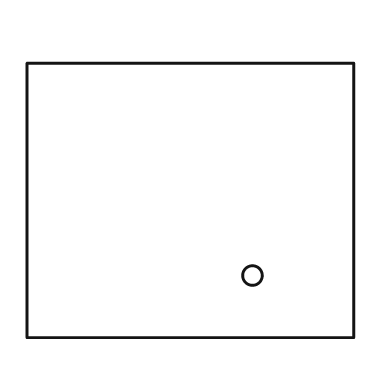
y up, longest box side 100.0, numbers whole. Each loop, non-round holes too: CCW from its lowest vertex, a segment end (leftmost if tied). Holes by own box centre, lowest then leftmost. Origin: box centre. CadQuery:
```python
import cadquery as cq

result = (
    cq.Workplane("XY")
    .moveTo(-50.0, -42.0)
    .lineTo(50.0, -42.0)
    .lineTo(50.0, 42.0)
    .lineTo(-50.0, 42.0)
    .close()
    .moveTo(19.0, -23.0)
    .circle(3.0)
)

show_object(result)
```